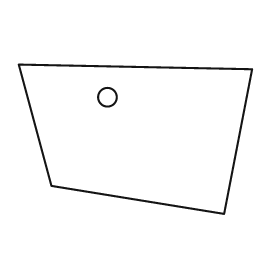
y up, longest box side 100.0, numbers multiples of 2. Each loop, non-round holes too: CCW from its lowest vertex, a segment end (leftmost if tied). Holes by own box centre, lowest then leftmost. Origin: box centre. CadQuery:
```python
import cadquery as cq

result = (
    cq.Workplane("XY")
    .moveTo(38.0, -32.0)
    .lineTo(50.0, 30.0)
    .lineTo(-50.0, 32.0)
    .lineTo(-36.0, -20.0)
    .close()
    .moveTo(-12.0, 18.0)
    .circle(4.0)
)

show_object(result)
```